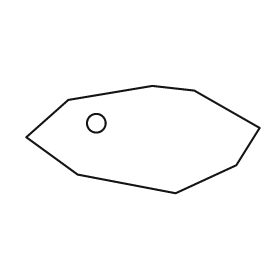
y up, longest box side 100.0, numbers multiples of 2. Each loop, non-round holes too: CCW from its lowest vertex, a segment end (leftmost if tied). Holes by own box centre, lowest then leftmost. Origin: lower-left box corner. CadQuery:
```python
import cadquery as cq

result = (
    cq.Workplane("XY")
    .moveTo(64.0, 0.0)
    .lineTo(90.0, 12.0)
    .lineTo(100.0, 28.0)
    .lineTo(72.0, 44.0)
    .lineTo(54.0, 46.0)
    .lineTo(18.0, 40.0)
    .lineTo(0.0, 24.0)
    .lineTo(22.0, 8.0)
    .close()
    .moveTo(30.0, 30.0)
    .circle(4.0)
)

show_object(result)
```